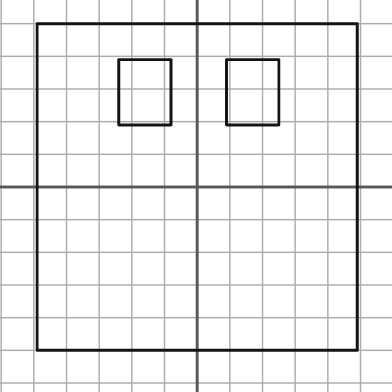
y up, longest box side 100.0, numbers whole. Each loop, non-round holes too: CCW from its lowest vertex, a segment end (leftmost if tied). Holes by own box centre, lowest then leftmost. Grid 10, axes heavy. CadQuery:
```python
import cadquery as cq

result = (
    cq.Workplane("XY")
    .moveTo(-49.0, -50.0)
    .lineTo(49.0, -50.0)
    .lineTo(49.0, 50.0)
    .lineTo(-49.0, 50.0)
    .close()
    .moveTo(-24.0, 19.0)
    .lineTo(-8.0, 19.0)
    .lineTo(-8.0, 39.0)
    .lineTo(-24.0, 39.0)
    .close()
    .moveTo(9.0, 19.0)
    .lineTo(25.0, 19.0)
    .lineTo(25.0, 39.0)
    .lineTo(9.0, 39.0)
    .close()
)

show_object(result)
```